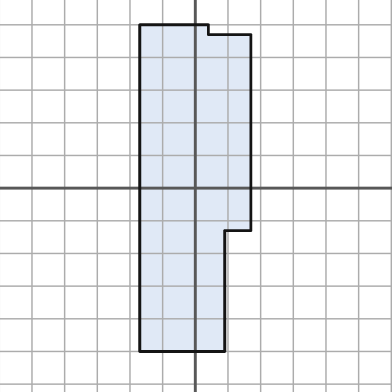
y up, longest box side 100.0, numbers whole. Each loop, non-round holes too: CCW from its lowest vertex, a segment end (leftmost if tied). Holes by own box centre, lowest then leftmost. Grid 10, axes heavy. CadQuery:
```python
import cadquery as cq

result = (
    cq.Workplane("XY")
    .moveTo(-17.0, -50.0)
    .lineTo(9.0, -50.0)
    .lineTo(9.0, -13.0)
    .lineTo(17.0, -13.0)
    .lineTo(17.0, 47.0)
    .lineTo(4.0, 47.0)
    .lineTo(4.0, 50.0)
    .lineTo(-17.0, 50.0)
    .close()
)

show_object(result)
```